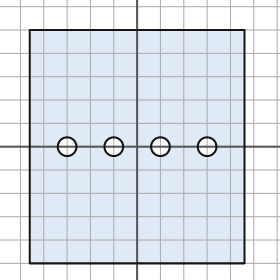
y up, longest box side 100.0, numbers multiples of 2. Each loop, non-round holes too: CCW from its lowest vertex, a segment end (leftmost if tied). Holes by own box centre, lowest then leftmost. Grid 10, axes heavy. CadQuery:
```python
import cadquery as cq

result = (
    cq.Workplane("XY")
    .moveTo(-46.0, -50.0)
    .lineTo(46.0, -50.0)
    .lineTo(46.0, 50.0)
    .lineTo(-46.0, 50.0)
    .close()
    .moveTo(-30.0, 0.0)
    .circle(4.0)
    .moveTo(-10.0, 0.0)
    .circle(4.0)
    .moveTo(10.0, 0.0)
    .circle(4.0)
    .moveTo(30.0, 0.0)
    .circle(4.0)
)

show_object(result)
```